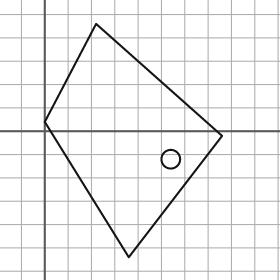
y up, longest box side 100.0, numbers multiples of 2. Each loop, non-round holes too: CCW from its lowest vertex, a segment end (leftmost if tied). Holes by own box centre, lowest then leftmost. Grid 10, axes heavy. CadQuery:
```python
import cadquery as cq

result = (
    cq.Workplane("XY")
    .moveTo(36.0, -54.0)
    .lineTo(76.0, -2.0)
    .lineTo(22.0, 46.0)
    .lineTo(0.0, 4.0)
    .close()
    .moveTo(54.0, -12.0)
    .circle(4.0)
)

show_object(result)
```